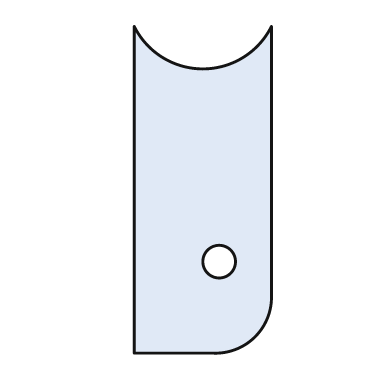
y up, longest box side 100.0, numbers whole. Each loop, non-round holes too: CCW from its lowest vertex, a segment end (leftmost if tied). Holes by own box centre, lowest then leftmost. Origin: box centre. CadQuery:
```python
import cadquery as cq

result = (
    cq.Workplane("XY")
    .moveTo(-21.0, -50.0)
    .lineTo(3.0, -50.0)
    .threePointArc((16.0, -45.0), (21.0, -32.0))
    .lineTo(21.0, 50.0)
    .threePointArc((0.0, 37.0), (-21.0, 50.0))
    .close()
    .moveTo(5.0, -22.0)
    .circle(5.0)
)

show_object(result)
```